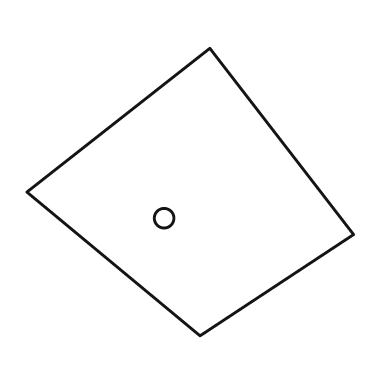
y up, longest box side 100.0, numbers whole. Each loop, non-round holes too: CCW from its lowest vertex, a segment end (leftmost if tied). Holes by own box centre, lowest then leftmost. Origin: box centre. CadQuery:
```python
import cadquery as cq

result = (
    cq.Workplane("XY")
    .moveTo(3.0, -44.0)
    .lineTo(50.0, -13.0)
    .lineTo(6.0, 44.0)
    .lineTo(-50.0, 0.0)
    .close()
    .moveTo(-8.0, -8.0)
    .circle(3.0)
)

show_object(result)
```